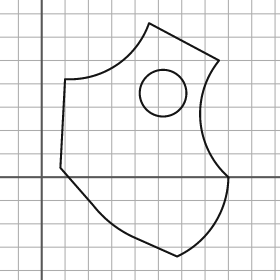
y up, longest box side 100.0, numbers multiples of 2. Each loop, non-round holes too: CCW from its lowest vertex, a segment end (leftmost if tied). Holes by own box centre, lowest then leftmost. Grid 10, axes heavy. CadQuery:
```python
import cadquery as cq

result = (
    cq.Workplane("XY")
    .moveTo(58.0, -34.0)
    .threePointArc((74.0, -20.0), (80.0, 0.0))
    .threePointArc((68.0, 24.0), (76.0, 50.0))
    .lineTo(46.0, 66.0)
    .threePointArc((32.0, 48.0), (10.0, 42.0))
    .lineTo(8.0, 4.0)
    .lineTo(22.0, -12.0)
    .threePointArc((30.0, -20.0), (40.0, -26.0))
    .close()
    .moveTo(52.0, 36.0)
    .circle(10.0)
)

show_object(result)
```